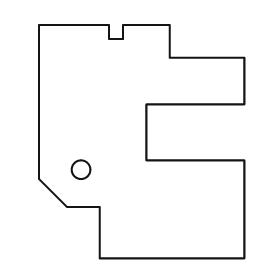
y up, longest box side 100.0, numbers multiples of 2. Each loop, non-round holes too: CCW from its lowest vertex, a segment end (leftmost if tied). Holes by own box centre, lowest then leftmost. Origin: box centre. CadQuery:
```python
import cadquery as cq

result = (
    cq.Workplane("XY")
    .moveTo(-18.0, -50.0)
    .lineTo(44.0, -50.0)
    .lineTo(44.0, -8.0)
    .lineTo(2.0, -8.0)
    .lineTo(2.0, 16.0)
    .lineTo(44.0, 16.0)
    .lineTo(44.0, 36.0)
    .lineTo(12.0, 36.0)
    .lineTo(12.0, 50.0)
    .lineTo(-8.0, 50.0)
    .lineTo(-8.0, 44.0)
    .lineTo(-14.0, 44.0)
    .lineTo(-14.0, 50.0)
    .lineTo(-44.0, 50.0)
    .lineTo(-44.0, -16.0)
    .lineTo(-32.0, -28.0)
    .lineTo(-18.0, -28.0)
    .close()
    .moveTo(-26.0, -12.0)
    .circle(4.0)
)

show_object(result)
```